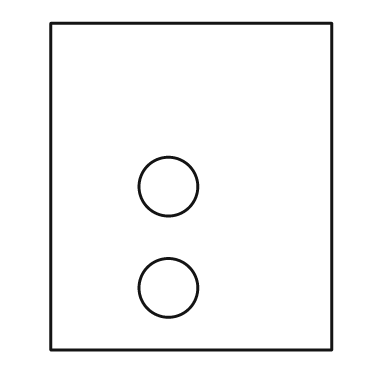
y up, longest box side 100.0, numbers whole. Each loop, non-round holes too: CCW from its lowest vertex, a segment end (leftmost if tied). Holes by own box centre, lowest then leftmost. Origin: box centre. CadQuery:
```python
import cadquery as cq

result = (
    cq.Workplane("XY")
    .moveTo(-43.0, -50.0)
    .lineTo(43.0, -50.0)
    .lineTo(43.0, 50.0)
    .lineTo(-43.0, 50.0)
    .close()
    .moveTo(-7.0, -31.0)
    .circle(9.0)
    .moveTo(-7.0, 0.0)
    .circle(9.0)
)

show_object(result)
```